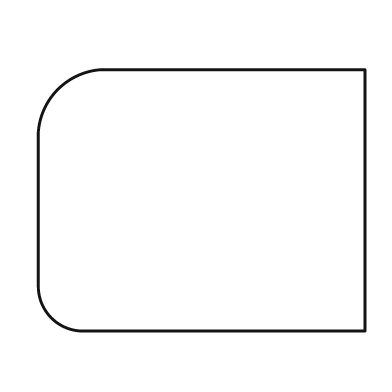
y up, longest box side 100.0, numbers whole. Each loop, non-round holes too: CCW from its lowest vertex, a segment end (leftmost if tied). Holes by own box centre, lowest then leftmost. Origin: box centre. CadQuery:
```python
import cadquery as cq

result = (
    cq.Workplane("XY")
    .moveTo(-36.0, -40.0)
    .lineTo(50.0, -40.0)
    .lineTo(50.0, 40.0)
    .lineTo(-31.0, 40.0)
    .threePointArc((-44.0, 34.0), (-50.0, 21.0))
    .lineTo(-50.0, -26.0)
    .threePointArc((-46.0, -36.0), (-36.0, -40.0))
    .close()
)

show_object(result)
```